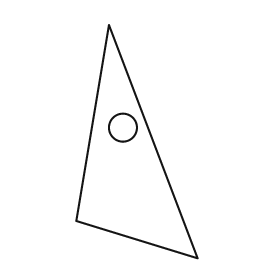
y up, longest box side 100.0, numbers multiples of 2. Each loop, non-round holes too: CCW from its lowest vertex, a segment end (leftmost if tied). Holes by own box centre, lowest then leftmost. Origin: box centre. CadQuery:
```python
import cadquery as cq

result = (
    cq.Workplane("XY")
    .moveTo(26.0, -50.0)
    .lineTo(-12.0, 50.0)
    .lineTo(-26.0, -34.0)
    .close()
    .moveTo(-6.0, 6.0)
    .circle(6.0)
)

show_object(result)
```